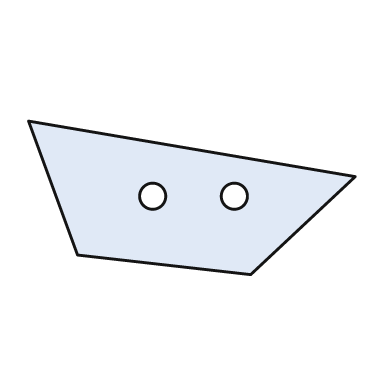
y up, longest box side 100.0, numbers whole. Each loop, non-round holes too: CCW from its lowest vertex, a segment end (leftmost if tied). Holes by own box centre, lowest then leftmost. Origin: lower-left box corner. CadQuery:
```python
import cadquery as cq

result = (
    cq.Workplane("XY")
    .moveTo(68.0, 0.0)
    .lineTo(100.0, 30.0)
    .lineTo(0.0, 47.0)
    .lineTo(15.0, 6.0)
    .close()
    .moveTo(38.0, 24.0)
    .circle(4.0)
    .moveTo(63.0, 24.0)
    .circle(4.0)
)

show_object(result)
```